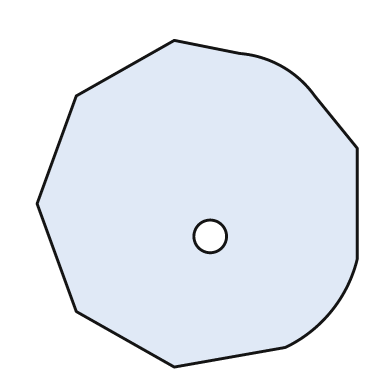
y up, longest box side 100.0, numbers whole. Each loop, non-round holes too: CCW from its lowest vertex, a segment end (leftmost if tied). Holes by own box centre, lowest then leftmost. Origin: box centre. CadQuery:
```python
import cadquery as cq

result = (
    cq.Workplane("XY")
    .moveTo(-7.0, -50.0)
    .lineTo(27.0, -44.0)
    .threePointArc((41.0, -33.0), (49.0, -17.0))
    .lineTo(49.0, 17.0)
    .lineTo(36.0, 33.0)
    .threePointArc((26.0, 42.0), (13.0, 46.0))
    .lineTo(-7.0, 50.0)
    .lineTo(-37.0, 33.0)
    .lineTo(-49.0, 0.0)
    .lineTo(-37.0, -33.0)
    .close()
    .moveTo(4.0, -10.0)
    .circle(5.0)
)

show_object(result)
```